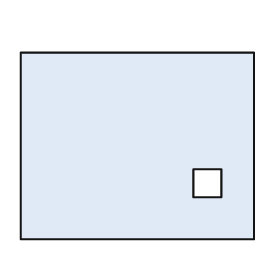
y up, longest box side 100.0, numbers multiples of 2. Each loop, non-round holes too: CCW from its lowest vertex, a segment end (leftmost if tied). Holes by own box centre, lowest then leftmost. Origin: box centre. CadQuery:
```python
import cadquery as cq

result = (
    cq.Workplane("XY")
    .moveTo(-50.0, -40.0)
    .lineTo(50.0, -40.0)
    .lineTo(50.0, 40.0)
    .lineTo(-50.0, 40.0)
    .close()
    .moveTo(24.0, -22.0)
    .lineTo(36.0, -22.0)
    .lineTo(36.0, -10.0)
    .lineTo(24.0, -10.0)
    .close()
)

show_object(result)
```